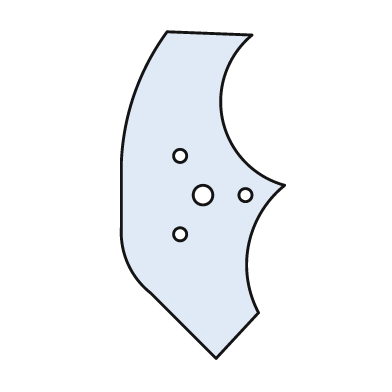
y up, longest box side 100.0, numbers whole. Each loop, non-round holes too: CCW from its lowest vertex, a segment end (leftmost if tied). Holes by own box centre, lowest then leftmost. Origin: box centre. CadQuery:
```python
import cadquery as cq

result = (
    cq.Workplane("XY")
    .moveTo(4.0, -50.0)
    .lineTo(17.0, -36.0)
    .threePointArc((14.0, -15.0), (25.0, 3.0))
    .threePointArc((6.0, 23.0), (15.0, 49.0))
    .lineTo(-11.0, 50.0)
    .threePointArc((-21.0, 31.0), (-25.0, 10.0))
    .lineTo(-25.0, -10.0)
    .threePointArc((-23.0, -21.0), (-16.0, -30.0))
    .close()
    .moveTo(-7.0, -12.0)
    .circle(2.0)
    .moveTo(0.0, 0.0)
    .circle(3.0)
    .moveTo(13.0, 0.0)
    .circle(2.0)
    .moveTo(-7.0, 12.0)
    .circle(2.0)
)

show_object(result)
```